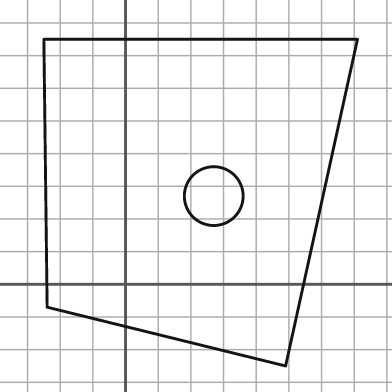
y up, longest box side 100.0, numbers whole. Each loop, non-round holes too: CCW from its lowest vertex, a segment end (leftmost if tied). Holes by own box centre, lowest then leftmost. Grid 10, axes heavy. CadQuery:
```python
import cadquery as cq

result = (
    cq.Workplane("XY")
    .moveTo(49.0, -25.0)
    .lineTo(71.0, 75.0)
    .lineTo(-25.0, 75.0)
    .lineTo(-24.0, -7.0)
    .close()
    .moveTo(27.0, 27.0)
    .circle(9.0)
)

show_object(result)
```